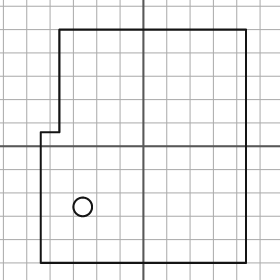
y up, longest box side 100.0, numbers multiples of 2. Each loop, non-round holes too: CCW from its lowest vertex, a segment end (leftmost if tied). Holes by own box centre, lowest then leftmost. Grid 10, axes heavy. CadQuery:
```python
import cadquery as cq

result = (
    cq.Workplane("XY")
    .moveTo(-44.0, -50.0)
    .lineTo(44.0, -50.0)
    .lineTo(44.0, 50.0)
    .lineTo(-36.0, 50.0)
    .lineTo(-36.0, 6.0)
    .lineTo(-44.0, 6.0)
    .close()
    .moveTo(-26.0, -26.0)
    .circle(4.0)
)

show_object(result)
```